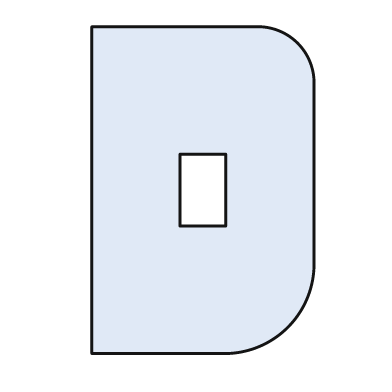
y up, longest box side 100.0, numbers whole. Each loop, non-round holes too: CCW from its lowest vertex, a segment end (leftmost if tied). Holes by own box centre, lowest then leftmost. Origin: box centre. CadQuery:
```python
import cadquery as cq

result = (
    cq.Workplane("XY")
    .moveTo(-34.0, -50.0)
    .lineTo(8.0, -50.0)
    .threePointArc((26.0, -42.0), (34.0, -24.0))
    .lineTo(34.0, 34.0)
    .threePointArc((29.0, 45.0), (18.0, 50.0))
    .lineTo(-34.0, 50.0)
    .close()
    .moveTo(-7.0, -11.0)
    .lineTo(7.0, -11.0)
    .lineTo(7.0, 11.0)
    .lineTo(-7.0, 11.0)
    .close()
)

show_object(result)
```